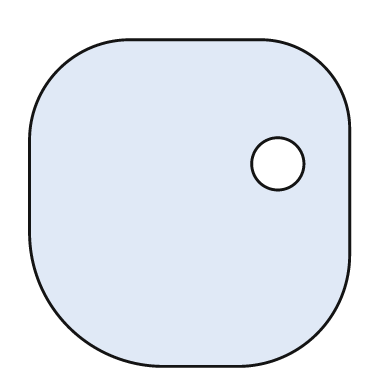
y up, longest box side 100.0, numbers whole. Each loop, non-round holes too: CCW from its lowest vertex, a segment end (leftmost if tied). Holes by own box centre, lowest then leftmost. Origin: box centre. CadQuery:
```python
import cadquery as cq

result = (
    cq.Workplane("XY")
    .moveTo(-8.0, -50.0)
    .lineTo(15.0, -50.0)
    .threePointArc((39.0, -40.0), (49.0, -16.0))
    .lineTo(49.0, 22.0)
    .threePointArc((41.0, 42.0), (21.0, 50.0))
    .lineTo(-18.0, 50.0)
    .threePointArc((-40.0, 41.0), (-49.0, 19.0))
    .lineTo(-49.0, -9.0)
    .threePointArc((-37.0, -38.0), (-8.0, -50.0))
    .close()
    .moveTo(27.0, 12.0)
    .circle(8.0)
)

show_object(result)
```